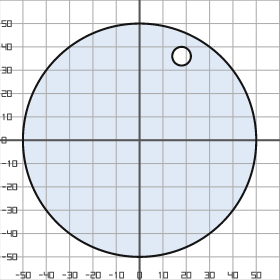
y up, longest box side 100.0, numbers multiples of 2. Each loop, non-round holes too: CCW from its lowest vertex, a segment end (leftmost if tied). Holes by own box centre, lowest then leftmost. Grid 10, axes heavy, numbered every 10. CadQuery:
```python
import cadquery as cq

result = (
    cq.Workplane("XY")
    .moveTo(0.0, 0.0)
    .circle(50.0)
    .moveTo(18.0, 36.0)
    .circle(4.0)
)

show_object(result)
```